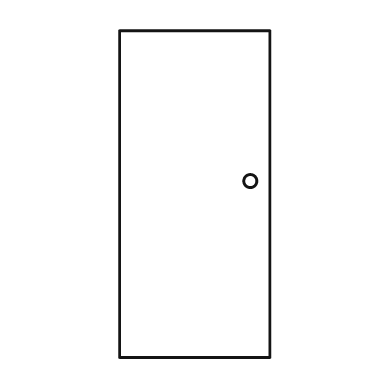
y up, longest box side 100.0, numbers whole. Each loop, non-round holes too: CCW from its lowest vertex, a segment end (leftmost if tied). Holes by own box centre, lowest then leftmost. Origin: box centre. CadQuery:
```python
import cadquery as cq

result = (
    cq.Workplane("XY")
    .moveTo(-23.0, -50.0)
    .lineTo(23.0, -50.0)
    .lineTo(23.0, 50.0)
    .lineTo(-23.0, 50.0)
    .close()
    .moveTo(17.0, 4.0)
    .circle(2.0)
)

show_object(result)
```